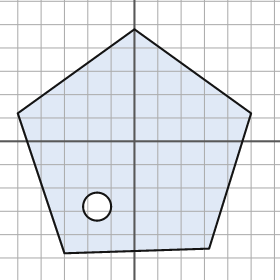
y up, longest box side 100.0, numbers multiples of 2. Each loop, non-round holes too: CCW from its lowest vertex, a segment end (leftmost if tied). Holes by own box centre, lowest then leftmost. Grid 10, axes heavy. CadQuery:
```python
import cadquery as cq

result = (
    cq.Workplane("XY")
    .moveTo(-30.0, -48.0)
    .lineTo(32.0, -46.0)
    .lineTo(50.0, 12.0)
    .lineTo(0.0, 48.0)
    .lineTo(-50.0, 12.0)
    .close()
    .moveTo(-16.0, -28.0)
    .circle(6.0)
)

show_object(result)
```